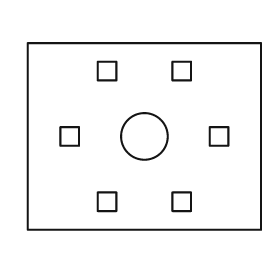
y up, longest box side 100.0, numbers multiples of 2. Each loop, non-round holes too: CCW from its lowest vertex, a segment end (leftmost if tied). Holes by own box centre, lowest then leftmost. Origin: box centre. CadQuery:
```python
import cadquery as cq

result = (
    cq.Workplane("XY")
    .moveTo(-50.0, -40.0)
    .lineTo(50.0, -40.0)
    .lineTo(50.0, 40.0)
    .lineTo(-50.0, 40.0)
    .close()
    .moveTo(-20.0, -32.0)
    .lineTo(-12.0, -32.0)
    .lineTo(-12.0, -24.0)
    .lineTo(-20.0, -24.0)
    .close()
    .moveTo(12.0, -32.0)
    .lineTo(20.0, -32.0)
    .lineTo(20.0, -24.0)
    .lineTo(12.0, -24.0)
    .close()
    .moveTo(-36.0, -4.0)
    .lineTo(-28.0, -4.0)
    .lineTo(-28.0, 4.0)
    .lineTo(-36.0, 4.0)
    .close()
    .moveTo(0.0, 0.0)
    .circle(10.0)
    .moveTo(28.0, -4.0)
    .lineTo(36.0, -4.0)
    .lineTo(36.0, 4.0)
    .lineTo(28.0, 4.0)
    .close()
    .moveTo(-20.0, 24.0)
    .lineTo(-12.0, 24.0)
    .lineTo(-12.0, 32.0)
    .lineTo(-20.0, 32.0)
    .close()
    .moveTo(12.0, 24.0)
    .lineTo(20.0, 24.0)
    .lineTo(20.0, 32.0)
    .lineTo(12.0, 32.0)
    .close()
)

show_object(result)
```